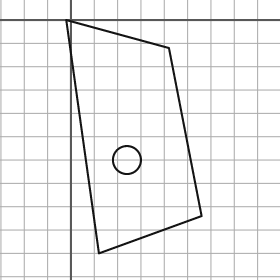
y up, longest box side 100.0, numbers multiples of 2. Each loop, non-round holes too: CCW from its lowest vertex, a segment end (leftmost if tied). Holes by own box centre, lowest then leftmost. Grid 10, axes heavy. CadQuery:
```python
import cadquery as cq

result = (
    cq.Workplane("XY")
    .moveTo(12.0, -100.0)
    .lineTo(56.0, -84.0)
    .lineTo(42.0, -12.0)
    .lineTo(-2.0, 0.0)
    .close()
    .moveTo(24.0, -60.0)
    .circle(6.0)
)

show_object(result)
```